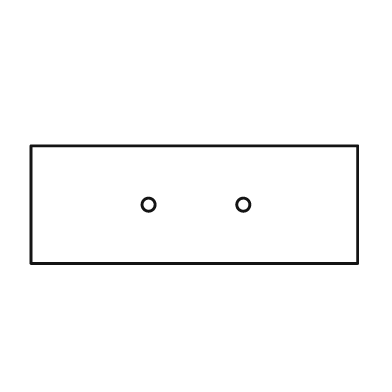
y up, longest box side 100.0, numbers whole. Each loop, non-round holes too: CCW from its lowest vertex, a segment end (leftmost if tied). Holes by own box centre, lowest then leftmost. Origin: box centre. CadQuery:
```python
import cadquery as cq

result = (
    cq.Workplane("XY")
    .moveTo(-50.0, -18.0)
    .lineTo(50.0, -18.0)
    .lineTo(50.0, 18.0)
    .lineTo(-50.0, 18.0)
    .close()
    .moveTo(-14.0, 0.0)
    .circle(2.0)
    .moveTo(15.0, 0.0)
    .circle(2.0)
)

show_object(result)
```